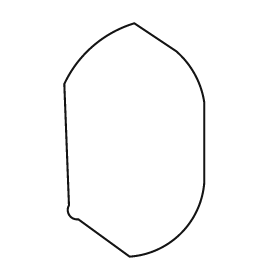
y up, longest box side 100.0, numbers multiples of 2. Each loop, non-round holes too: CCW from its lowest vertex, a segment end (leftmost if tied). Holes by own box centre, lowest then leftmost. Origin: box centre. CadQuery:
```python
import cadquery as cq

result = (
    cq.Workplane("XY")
    .moveTo(-2.0, -50.0)
    .threePointArc((20.0, -40.0), (30.0, -18.0))
    .lineTo(30.0, 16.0)
    .threePointArc((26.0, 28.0), (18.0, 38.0))
    .lineTo(0.0, 50.0)
    .threePointArc((-18.0, 40.0), (-30.0, 24.0))
    .lineTo(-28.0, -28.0)
    .threePointArc((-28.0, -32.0), (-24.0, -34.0))
    .close()
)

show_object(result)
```